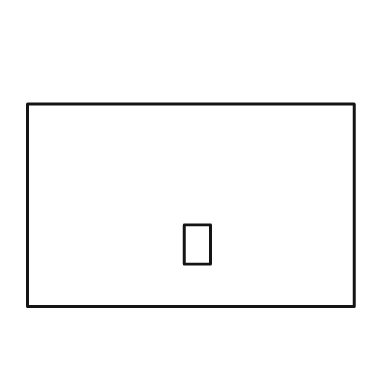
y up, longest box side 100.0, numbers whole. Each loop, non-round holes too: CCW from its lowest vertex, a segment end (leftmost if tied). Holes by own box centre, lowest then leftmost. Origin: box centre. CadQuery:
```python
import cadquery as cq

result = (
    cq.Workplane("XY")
    .moveTo(-50.0, -31.0)
    .lineTo(50.0, -31.0)
    .lineTo(50.0, 31.0)
    .lineTo(-50.0, 31.0)
    .close()
    .moveTo(-2.0, -18.0)
    .lineTo(6.0, -18.0)
    .lineTo(6.0, -6.0)
    .lineTo(-2.0, -6.0)
    .close()
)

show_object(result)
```